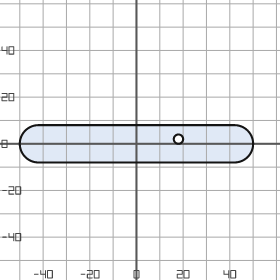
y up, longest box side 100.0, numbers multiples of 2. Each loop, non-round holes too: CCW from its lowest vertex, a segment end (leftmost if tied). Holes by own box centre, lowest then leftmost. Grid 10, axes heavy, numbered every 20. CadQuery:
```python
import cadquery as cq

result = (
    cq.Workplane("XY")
    .moveTo(-42.0, -8.0)
    .lineTo(42.0, -8.0)
    .threePointArc((50.0, 0.0), (42.0, 8.0))
    .lineTo(-42.0, 8.0)
    .threePointArc((-50.0, 0.0), (-42.0, -8.0))
    .close()
    .moveTo(18.0, 2.0)
    .circle(2.0)
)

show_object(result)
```